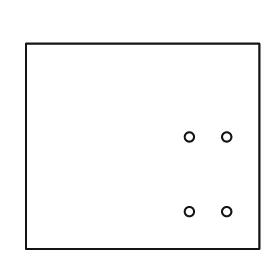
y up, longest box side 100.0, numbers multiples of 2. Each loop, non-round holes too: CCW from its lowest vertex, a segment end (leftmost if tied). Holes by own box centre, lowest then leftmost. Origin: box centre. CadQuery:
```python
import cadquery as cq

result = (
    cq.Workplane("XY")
    .moveTo(-50.0, -44.0)
    .lineTo(50.0, -44.0)
    .lineTo(50.0, 44.0)
    .lineTo(-50.0, 44.0)
    .close()
    .moveTo(20.0, -28.0)
    .circle(2.0)
    .moveTo(36.0, -28.0)
    .circle(2.0)
    .moveTo(20.0, 4.0)
    .circle(2.0)
    .moveTo(36.0, 4.0)
    .circle(2.0)
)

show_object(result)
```